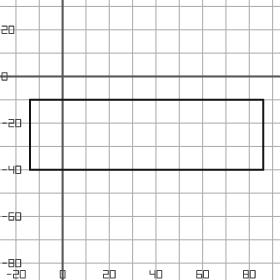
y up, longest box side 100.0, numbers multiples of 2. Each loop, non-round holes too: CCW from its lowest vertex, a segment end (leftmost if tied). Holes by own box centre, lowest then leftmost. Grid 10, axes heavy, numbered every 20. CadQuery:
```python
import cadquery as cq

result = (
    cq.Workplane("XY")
    .moveTo(-14.0, -40.0)
    .lineTo(86.0, -40.0)
    .lineTo(86.0, -10.0)
    .lineTo(-14.0, -10.0)
    .close()
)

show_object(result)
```